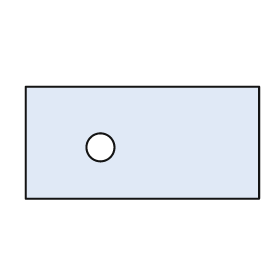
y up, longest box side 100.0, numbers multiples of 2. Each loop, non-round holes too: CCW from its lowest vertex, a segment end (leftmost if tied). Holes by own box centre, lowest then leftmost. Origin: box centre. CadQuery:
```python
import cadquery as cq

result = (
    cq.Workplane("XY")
    .moveTo(-50.0, -24.0)
    .lineTo(50.0, -24.0)
    .lineTo(50.0, 24.0)
    .lineTo(-50.0, 24.0)
    .close()
    .moveTo(-18.0, -2.0)
    .circle(6.0)
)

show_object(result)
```